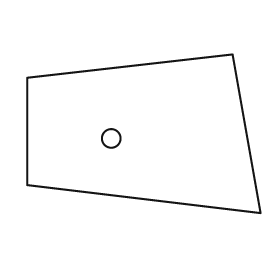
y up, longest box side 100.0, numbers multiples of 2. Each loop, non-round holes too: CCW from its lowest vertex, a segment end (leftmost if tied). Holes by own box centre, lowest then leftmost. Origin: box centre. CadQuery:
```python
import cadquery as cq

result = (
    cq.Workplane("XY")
    .moveTo(50.0, -34.0)
    .lineTo(38.0, 34.0)
    .lineTo(-50.0, 24.0)
    .lineTo(-50.0, -22.0)
    .close()
    .moveTo(-14.0, -2.0)
    .circle(4.0)
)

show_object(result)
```